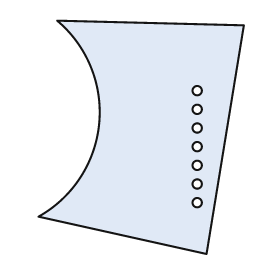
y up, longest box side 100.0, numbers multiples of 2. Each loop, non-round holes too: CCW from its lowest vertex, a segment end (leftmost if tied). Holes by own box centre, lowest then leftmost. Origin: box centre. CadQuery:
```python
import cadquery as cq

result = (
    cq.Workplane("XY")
    .moveTo(28.0, -50.0)
    .lineTo(44.0, 48.0)
    .lineTo(-36.0, 50.0)
    .threePointArc((-18.0, 6.0), (-44.0, -34.0))
    .close()
    .moveTo(24.0, -28.0)
    .circle(2.0)
    .moveTo(24.0, -20.0)
    .circle(2.0)
    .moveTo(24.0, -12.0)
    .circle(2.0)
    .moveTo(24.0, -4.0)
    .circle(2.0)
    .moveTo(24.0, 4.0)
    .circle(2.0)
    .moveTo(24.0, 12.0)
    .circle(2.0)
    .moveTo(24.0, 20.0)
    .circle(2.0)
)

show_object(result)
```